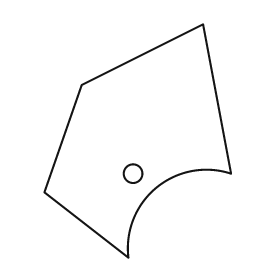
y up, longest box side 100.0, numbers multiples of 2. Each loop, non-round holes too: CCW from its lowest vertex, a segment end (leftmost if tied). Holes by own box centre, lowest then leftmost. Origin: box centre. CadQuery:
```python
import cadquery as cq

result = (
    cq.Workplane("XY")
    .moveTo(-4.0, -50.0)
    .threePointArc((8.0, -20.0), (40.0, -14.0))
    .lineTo(28.0, 50.0)
    .lineTo(-24.0, 24.0)
    .lineTo(-40.0, -22.0)
    .close()
    .moveTo(-2.0, -14.0)
    .circle(4.0)
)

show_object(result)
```